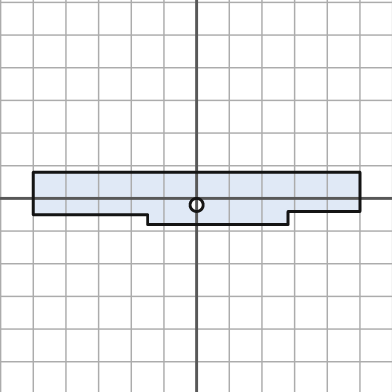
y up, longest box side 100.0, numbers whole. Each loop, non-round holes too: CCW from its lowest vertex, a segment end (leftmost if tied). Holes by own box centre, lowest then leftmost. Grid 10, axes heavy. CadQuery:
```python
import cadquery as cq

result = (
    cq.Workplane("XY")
    .moveTo(-15.0, -8.0)
    .lineTo(28.0, -8.0)
    .lineTo(28.0, -4.0)
    .lineTo(50.0, -4.0)
    .lineTo(50.0, 8.0)
    .lineTo(-50.0, 8.0)
    .lineTo(-50.0, -5.0)
    .lineTo(-15.0, -5.0)
    .close()
    .moveTo(0.0, -2.0)
    .circle(2.0)
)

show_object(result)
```